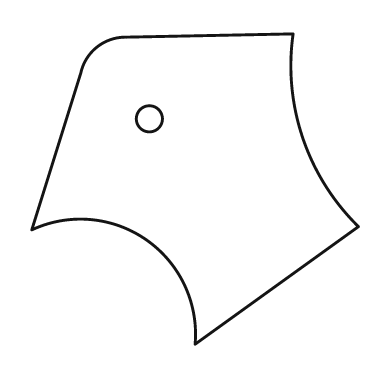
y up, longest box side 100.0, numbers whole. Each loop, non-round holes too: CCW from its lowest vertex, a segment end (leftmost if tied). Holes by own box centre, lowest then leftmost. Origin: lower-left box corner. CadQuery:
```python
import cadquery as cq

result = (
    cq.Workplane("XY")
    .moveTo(50.0, 0.0)
    .lineTo(100.0, 36.0)
    .threePointArc((83.0, 63.0), (80.0, 95.0))
    .lineTo(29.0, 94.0)
    .threePointArc((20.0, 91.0), (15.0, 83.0))
    .lineTo(0.0, 35.0)
    .threePointArc((35.0, 32.0), (50.0, 0.0))
    .close()
    .moveTo(36.0, 69.0)
    .circle(4.0)
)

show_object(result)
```